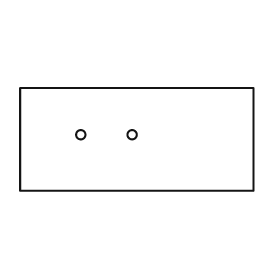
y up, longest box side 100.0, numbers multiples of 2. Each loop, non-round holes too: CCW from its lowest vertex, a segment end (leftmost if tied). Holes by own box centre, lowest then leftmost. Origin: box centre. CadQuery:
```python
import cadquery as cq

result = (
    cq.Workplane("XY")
    .moveTo(-50.0, -22.0)
    .lineTo(50.0, -22.0)
    .lineTo(50.0, 22.0)
    .lineTo(-50.0, 22.0)
    .close()
    .moveTo(-24.0, 2.0)
    .circle(2.0)
    .moveTo(-2.0, 2.0)
    .circle(2.0)
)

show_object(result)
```